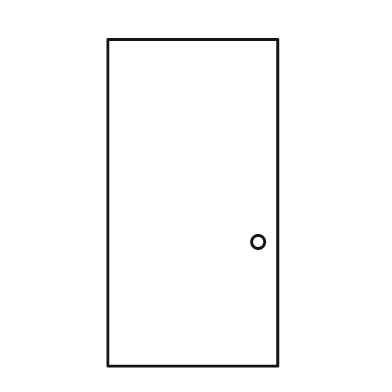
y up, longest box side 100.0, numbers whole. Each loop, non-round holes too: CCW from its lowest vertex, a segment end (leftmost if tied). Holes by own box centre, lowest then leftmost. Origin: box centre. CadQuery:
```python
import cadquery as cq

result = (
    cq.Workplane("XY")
    .moveTo(-26.0, -50.0)
    .lineTo(26.0, -50.0)
    .lineTo(26.0, 50.0)
    .lineTo(-26.0, 50.0)
    .close()
    .moveTo(20.0, -12.0)
    .circle(2.0)
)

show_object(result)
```